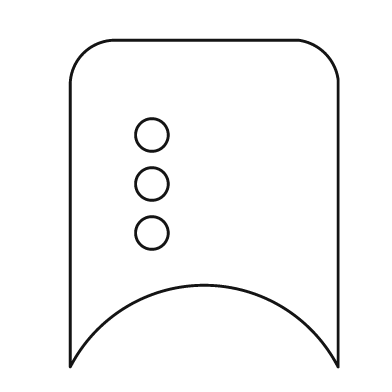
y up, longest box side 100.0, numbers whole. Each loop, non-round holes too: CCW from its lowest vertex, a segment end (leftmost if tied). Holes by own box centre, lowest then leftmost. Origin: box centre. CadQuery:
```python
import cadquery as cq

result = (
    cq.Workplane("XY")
    .moveTo(-41.0, -50.0)
    .threePointArc((0.0, -25.0), (41.0, -50.0))
    .lineTo(41.0, 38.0)
    .threePointArc((37.0, 46.0), (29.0, 50.0))
    .lineTo(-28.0, 50.0)
    .threePointArc((-37.0, 46.0), (-41.0, 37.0))
    .close()
    .moveTo(-16.0, -9.0)
    .circle(5.0)
    .moveTo(-16.0, 6.0)
    .circle(5.0)
    .moveTo(-16.0, 21.0)
    .circle(5.0)
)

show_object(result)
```